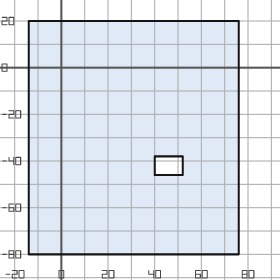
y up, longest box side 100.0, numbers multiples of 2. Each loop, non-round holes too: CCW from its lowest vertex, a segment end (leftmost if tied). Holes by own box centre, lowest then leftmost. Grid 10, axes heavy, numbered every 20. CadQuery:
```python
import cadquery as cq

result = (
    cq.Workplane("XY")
    .moveTo(-14.0, -80.0)
    .lineTo(76.0, -80.0)
    .lineTo(76.0, 20.0)
    .lineTo(-14.0, 20.0)
    .close()
    .moveTo(40.0, -46.0)
    .lineTo(52.0, -46.0)
    .lineTo(52.0, -38.0)
    .lineTo(40.0, -38.0)
    .close()
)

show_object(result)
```